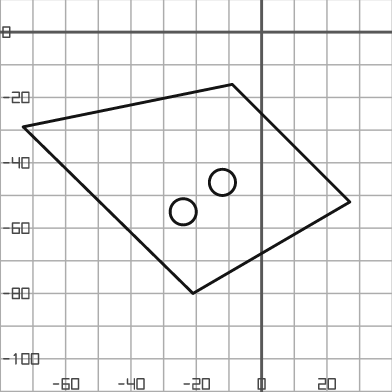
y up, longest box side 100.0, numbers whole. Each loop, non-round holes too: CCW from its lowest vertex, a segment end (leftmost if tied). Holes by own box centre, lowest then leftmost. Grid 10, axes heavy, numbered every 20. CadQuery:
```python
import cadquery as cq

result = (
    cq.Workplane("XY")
    .moveTo(-21.0, -80.0)
    .lineTo(27.0, -52.0)
    .lineTo(-9.0, -16.0)
    .lineTo(-73.0, -29.0)
    .close()
    .moveTo(-24.0, -55.0)
    .circle(4.0)
    .moveTo(-12.0, -46.0)
    .circle(4.0)
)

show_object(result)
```